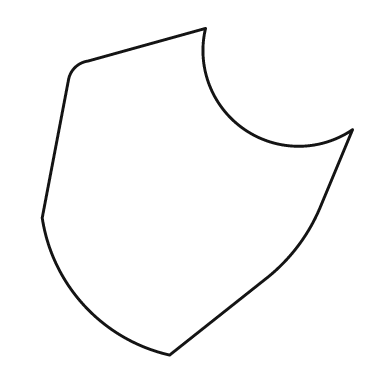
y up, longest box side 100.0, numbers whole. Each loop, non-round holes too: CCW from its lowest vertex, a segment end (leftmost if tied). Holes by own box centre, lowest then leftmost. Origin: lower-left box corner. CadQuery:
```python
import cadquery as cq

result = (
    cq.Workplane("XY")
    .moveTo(39.0, 0.0)
    .lineTo(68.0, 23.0)
    .threePointArc((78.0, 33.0), (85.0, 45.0))
    .lineTo(95.0, 69.0)
    .threePointArc((62.0, 69.0), (50.0, 100.0))
    .lineTo(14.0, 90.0)
    .threePointArc((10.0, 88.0), (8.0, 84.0))
    .lineTo(0.0, 42.0)
    .threePointArc((13.0, 15.0), (39.0, 0.0))
    .close()
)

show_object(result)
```